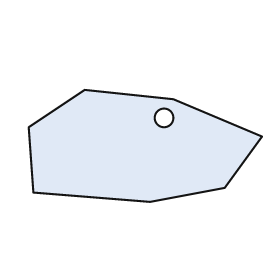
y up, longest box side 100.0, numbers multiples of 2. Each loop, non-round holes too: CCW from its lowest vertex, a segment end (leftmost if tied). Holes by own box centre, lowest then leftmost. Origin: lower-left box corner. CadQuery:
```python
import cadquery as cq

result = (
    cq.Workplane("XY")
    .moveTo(52.0, 0.0)
    .lineTo(84.0, 6.0)
    .lineTo(100.0, 28.0)
    .lineTo(62.0, 44.0)
    .lineTo(24.0, 48.0)
    .lineTo(0.0, 32.0)
    .lineTo(2.0, 4.0)
    .close()
    .moveTo(58.0, 36.0)
    .circle(4.0)
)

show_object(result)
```